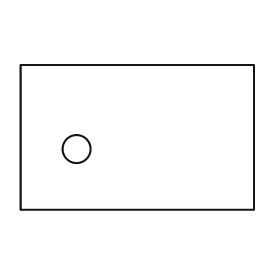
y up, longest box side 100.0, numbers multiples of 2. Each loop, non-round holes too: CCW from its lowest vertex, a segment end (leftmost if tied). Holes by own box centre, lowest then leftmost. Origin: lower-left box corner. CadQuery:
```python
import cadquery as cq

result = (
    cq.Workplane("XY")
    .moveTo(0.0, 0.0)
    .lineTo(100.0, 0.0)
    .lineTo(100.0, 62.0)
    .lineTo(0.0, 62.0)
    .close()
    .moveTo(24.0, 26.0)
    .circle(6.0)
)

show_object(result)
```